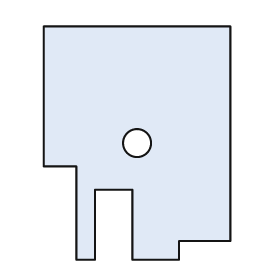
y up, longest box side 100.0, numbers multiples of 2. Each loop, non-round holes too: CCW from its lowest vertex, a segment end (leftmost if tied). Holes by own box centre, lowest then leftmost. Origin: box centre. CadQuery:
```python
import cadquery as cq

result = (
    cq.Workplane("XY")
    .moveTo(-26.0, -50.0)
    .lineTo(-18.0, -50.0)
    .lineTo(-18.0, -20.0)
    .lineTo(-2.0, -20.0)
    .lineTo(-2.0, -50.0)
    .lineTo(18.0, -50.0)
    .lineTo(18.0, -42.0)
    .lineTo(40.0, -42.0)
    .lineTo(40.0, 50.0)
    .lineTo(-40.0, 50.0)
    .lineTo(-40.0, -10.0)
    .lineTo(-26.0, -10.0)
    .close()
    .moveTo(0.0, 0.0)
    .circle(6.0)
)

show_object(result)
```